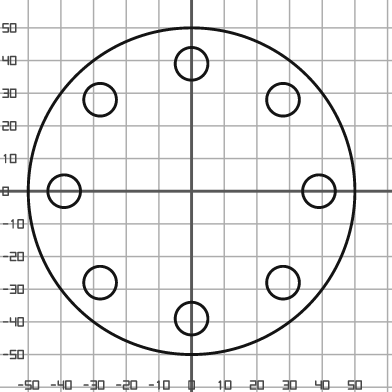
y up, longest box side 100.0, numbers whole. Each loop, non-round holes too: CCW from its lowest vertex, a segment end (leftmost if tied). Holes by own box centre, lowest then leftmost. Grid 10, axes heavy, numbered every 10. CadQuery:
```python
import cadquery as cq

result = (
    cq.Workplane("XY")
    .moveTo(0.0, 0.0)
    .circle(50.0)
    .moveTo(0.0, -39.0)
    .circle(5.0)
    .moveTo(-28.0, -28.0)
    .circle(5.0)
    .moveTo(28.0, -28.0)
    .circle(5.0)
    .moveTo(-39.0, 0.0)
    .circle(5.0)
    .moveTo(39.0, 0.0)
    .circle(5.0)
    .moveTo(-28.0, 28.0)
    .circle(5.0)
    .moveTo(28.0, 28.0)
    .circle(5.0)
    .moveTo(0.0, 39.0)
    .circle(5.0)
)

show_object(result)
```